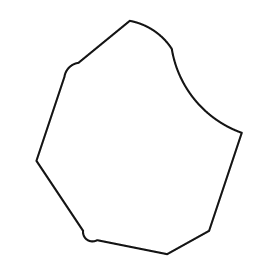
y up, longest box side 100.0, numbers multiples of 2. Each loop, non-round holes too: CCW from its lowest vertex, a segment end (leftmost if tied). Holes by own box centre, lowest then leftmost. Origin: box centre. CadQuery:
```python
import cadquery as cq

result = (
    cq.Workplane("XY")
    .moveTo(12.0, -50.0)
    .lineTo(30.0, -40.0)
    .lineTo(44.0, 2.0)
    .threePointArc((24.0, 16.0), (14.0, 38.0))
    .threePointArc((6.0, 46.0), (-4.0, 50.0))
    .lineTo(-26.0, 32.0)
    .threePointArc((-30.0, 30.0), (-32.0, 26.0))
    .lineTo(-44.0, -10.0)
    .lineTo(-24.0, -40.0)
    .threePointArc((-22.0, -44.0), (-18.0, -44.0))
    .close()
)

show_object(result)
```